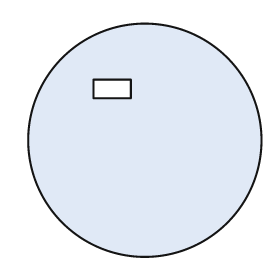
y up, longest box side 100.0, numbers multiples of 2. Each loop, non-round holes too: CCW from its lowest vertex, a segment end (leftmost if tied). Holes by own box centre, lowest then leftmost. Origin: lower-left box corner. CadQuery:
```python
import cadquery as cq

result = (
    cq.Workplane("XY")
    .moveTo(50.0, 50.0)
    .circle(50.0)
    .moveTo(28.0, 68.0)
    .lineTo(44.0, 68.0)
    .lineTo(44.0, 76.0)
    .lineTo(28.0, 76.0)
    .close()
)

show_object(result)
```